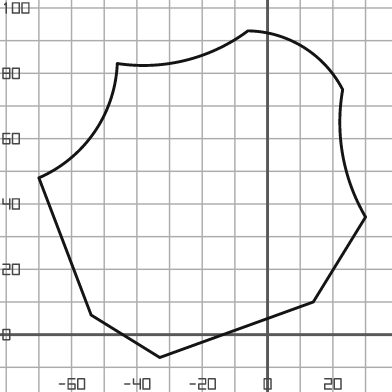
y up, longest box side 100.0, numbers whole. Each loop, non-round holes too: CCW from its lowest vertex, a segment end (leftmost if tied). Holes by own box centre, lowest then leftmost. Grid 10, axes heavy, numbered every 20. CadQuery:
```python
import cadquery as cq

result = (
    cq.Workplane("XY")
    .moveTo(-33.0, -7.0)
    .lineTo(14.0, 10.0)
    .lineTo(30.0, 36.0)
    .threePointArc((23.0, 55.0), (23.0, 75.0))
    .threePointArc((11.0, 88.0), (-6.0, 93.0))
    .threePointArc((-25.0, 84.0), (-46.0, 83.0))
    .threePointArc((-53.0, 62.0), (-70.0, 48.0))
    .lineTo(-54.0, 6.0)
    .close()
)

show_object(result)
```